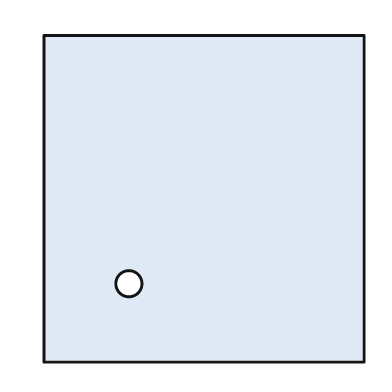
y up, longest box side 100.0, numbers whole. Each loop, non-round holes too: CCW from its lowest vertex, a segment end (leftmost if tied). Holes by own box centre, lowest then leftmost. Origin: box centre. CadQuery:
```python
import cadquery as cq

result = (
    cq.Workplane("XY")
    .moveTo(-49.0, -50.0)
    .lineTo(49.0, -50.0)
    .lineTo(49.0, 50.0)
    .lineTo(-49.0, 50.0)
    .close()
    .moveTo(-23.0, -26.0)
    .circle(4.0)
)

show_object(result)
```